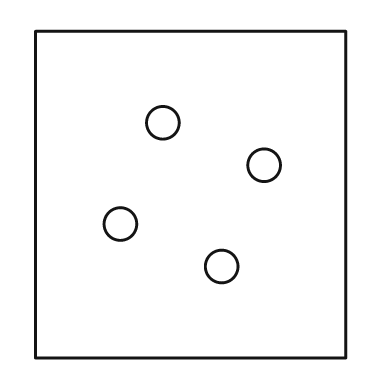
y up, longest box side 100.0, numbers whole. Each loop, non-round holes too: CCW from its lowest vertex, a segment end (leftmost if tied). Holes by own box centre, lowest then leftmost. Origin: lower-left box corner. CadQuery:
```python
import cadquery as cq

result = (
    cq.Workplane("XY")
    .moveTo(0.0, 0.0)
    .lineTo(95.0, 0.0)
    .lineTo(95.0, 100.0)
    .lineTo(0.0, 100.0)
    .close()
    .moveTo(57.0, 28.0)
    .circle(5.0)
    .moveTo(26.0, 41.0)
    .circle(5.0)
    .moveTo(70.0, 59.0)
    .circle(5.0)
    .moveTo(39.0, 72.0)
    .circle(5.0)
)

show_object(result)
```